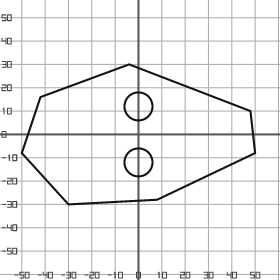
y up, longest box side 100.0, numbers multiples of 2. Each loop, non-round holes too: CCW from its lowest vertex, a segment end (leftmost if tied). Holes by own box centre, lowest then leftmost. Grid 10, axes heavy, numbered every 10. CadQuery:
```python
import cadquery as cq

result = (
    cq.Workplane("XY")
    .moveTo(-30.0, -30.0)
    .lineTo(8.0, -28.0)
    .lineTo(50.0, -8.0)
    .lineTo(48.0, 10.0)
    .lineTo(-4.0, 30.0)
    .lineTo(-42.0, 16.0)
    .lineTo(-50.0, -8.0)
    .close()
    .moveTo(0.0, -12.0)
    .circle(6.0)
    .moveTo(0.0, 12.0)
    .circle(6.0)
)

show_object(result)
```